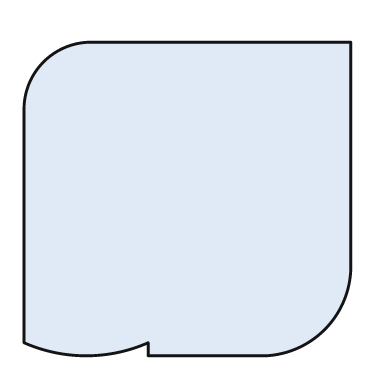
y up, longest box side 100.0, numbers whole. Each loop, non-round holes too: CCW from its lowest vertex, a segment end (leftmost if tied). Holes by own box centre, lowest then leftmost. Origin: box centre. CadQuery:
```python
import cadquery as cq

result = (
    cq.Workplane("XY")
    .moveTo(-12.0, -48.0)
    .lineTo(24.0, -48.0)
    .threePointArc((42.0, -40.0), (50.0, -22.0))
    .lineTo(50.0, 48.0)
    .lineTo(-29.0, 48.0)
    .threePointArc((-44.0, 42.0), (-50.0, 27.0))
    .lineTo(-50.0, -44.0)
    .threePointArc((-31.0, -48.0), (-12.0, -44.0))
    .close()
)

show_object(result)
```